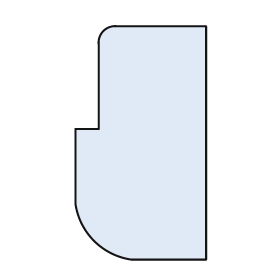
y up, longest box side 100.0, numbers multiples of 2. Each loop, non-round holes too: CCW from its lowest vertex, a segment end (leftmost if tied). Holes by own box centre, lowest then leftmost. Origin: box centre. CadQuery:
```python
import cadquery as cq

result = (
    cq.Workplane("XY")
    .moveTo(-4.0, -50.0)
    .lineTo(28.0, -50.0)
    .lineTo(28.0, 50.0)
    .lineTo(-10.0, 50.0)
    .threePointArc((-16.0, 48.0), (-18.0, 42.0))
    .lineTo(-18.0, 6.0)
    .lineTo(-28.0, 6.0)
    .lineTo(-28.0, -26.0)
    .threePointArc((-20.0, -42.0), (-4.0, -50.0))
    .close()
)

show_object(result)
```